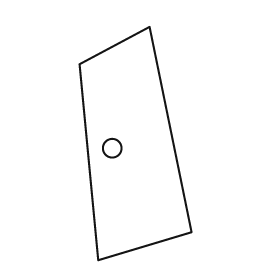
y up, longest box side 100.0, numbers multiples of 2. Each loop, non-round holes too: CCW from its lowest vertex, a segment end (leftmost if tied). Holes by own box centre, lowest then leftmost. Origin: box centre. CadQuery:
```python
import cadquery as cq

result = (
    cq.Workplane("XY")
    .moveTo(-16.0, -50.0)
    .lineTo(24.0, -38.0)
    .lineTo(6.0, 50.0)
    .lineTo(-24.0, 34.0)
    .close()
    .moveTo(-10.0, -2.0)
    .circle(4.0)
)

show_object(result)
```